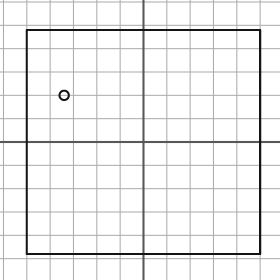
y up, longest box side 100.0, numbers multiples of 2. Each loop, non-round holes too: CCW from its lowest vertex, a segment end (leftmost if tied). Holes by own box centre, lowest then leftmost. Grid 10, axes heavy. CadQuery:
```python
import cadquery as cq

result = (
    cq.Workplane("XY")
    .moveTo(-50.0, -48.0)
    .lineTo(50.0, -48.0)
    .lineTo(50.0, 48.0)
    .lineTo(-50.0, 48.0)
    .close()
    .moveTo(-34.0, 20.0)
    .circle(2.0)
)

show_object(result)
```